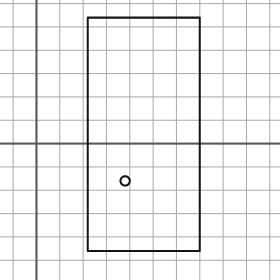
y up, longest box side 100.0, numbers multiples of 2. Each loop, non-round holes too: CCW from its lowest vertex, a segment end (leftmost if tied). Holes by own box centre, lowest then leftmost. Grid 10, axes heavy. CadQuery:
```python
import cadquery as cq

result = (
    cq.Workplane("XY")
    .moveTo(22.0, -46.0)
    .lineTo(70.0, -46.0)
    .lineTo(70.0, 54.0)
    .lineTo(22.0, 54.0)
    .close()
    .moveTo(38.0, -16.0)
    .circle(2.0)
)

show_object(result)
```